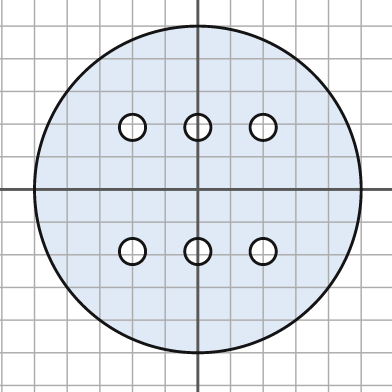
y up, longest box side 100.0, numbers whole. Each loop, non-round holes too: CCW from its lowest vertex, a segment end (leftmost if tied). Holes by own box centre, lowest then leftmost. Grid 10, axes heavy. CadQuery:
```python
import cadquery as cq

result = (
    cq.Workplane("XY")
    .moveTo(0.0, 0.0)
    .circle(50.0)
    .moveTo(-20.0, -19.0)
    .circle(4.0)
    .moveTo(0.0, -19.0)
    .circle(4.0)
    .moveTo(20.0, -19.0)
    .circle(4.0)
    .moveTo(-20.0, 19.0)
    .circle(4.0)
    .moveTo(0.0, 19.0)
    .circle(4.0)
    .moveTo(20.0, 19.0)
    .circle(4.0)
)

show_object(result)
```